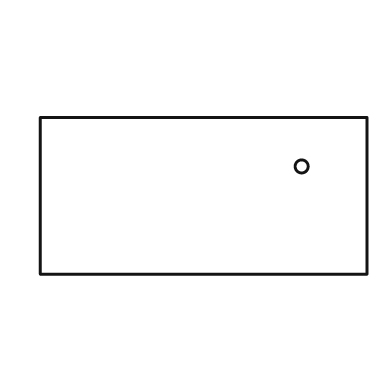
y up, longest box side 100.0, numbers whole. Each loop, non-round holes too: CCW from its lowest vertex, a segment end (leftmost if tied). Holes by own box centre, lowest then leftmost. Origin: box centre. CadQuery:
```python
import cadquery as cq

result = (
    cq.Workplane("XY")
    .moveTo(-50.0, -24.0)
    .lineTo(50.0, -24.0)
    .lineTo(50.0, 24.0)
    .lineTo(-50.0, 24.0)
    .close()
    .moveTo(30.0, 9.0)
    .circle(2.0)
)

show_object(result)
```